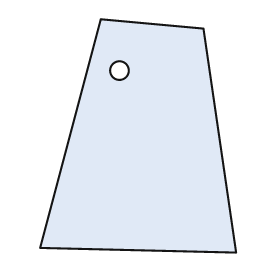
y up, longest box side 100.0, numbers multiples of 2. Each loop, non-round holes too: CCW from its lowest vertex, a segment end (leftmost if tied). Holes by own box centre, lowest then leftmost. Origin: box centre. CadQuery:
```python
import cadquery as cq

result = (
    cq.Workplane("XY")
    .moveTo(42.0, -50.0)
    .lineTo(28.0, 46.0)
    .lineTo(-16.0, 50.0)
    .lineTo(-42.0, -48.0)
    .close()
    .moveTo(-8.0, 28.0)
    .circle(4.0)
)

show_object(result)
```